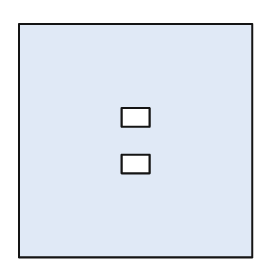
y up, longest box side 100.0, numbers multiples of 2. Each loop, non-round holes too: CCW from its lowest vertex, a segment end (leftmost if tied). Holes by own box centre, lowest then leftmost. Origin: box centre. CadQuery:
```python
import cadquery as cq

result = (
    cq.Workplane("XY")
    .moveTo(-50.0, -50.0)
    .lineTo(50.0, -50.0)
    .lineTo(50.0, 50.0)
    .lineTo(-50.0, 50.0)
    .close()
    .moveTo(-6.0, -14.0)
    .lineTo(6.0, -14.0)
    .lineTo(6.0, -6.0)
    .lineTo(-6.0, -6.0)
    .close()
    .moveTo(-6.0, 6.0)
    .lineTo(6.0, 6.0)
    .lineTo(6.0, 14.0)
    .lineTo(-6.0, 14.0)
    .close()
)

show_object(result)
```